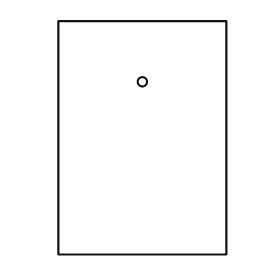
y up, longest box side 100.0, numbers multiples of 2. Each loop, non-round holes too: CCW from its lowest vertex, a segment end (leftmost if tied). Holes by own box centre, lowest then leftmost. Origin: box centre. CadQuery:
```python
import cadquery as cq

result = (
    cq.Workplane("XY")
    .moveTo(-36.0, -50.0)
    .lineTo(36.0, -50.0)
    .lineTo(36.0, 50.0)
    .lineTo(-36.0, 50.0)
    .close()
    .moveTo(0.0, 24.0)
    .circle(2.0)
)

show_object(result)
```